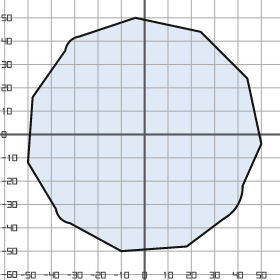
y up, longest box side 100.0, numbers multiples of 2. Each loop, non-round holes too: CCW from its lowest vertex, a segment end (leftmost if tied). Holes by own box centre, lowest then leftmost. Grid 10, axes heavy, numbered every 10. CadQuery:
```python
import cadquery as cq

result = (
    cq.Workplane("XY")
    .moveTo(-10.0, -50.0)
    .lineTo(18.0, -48.0)
    .lineTo(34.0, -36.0)
    .threePointArc((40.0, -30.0), (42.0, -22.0))
    .lineTo(50.0, -4.0)
    .lineTo(44.0, 24.0)
    .lineTo(24.0, 44.0)
    .lineTo(-4.0, 50.0)
    .lineTo(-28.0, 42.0)
    .threePointArc((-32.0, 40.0), (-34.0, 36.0))
    .lineTo(-48.0, 16.0)
    .lineTo(-50.0, -12.0)
    .lineTo(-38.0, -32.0)
    .threePointArc((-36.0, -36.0), (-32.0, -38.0))
    .close()
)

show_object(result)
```